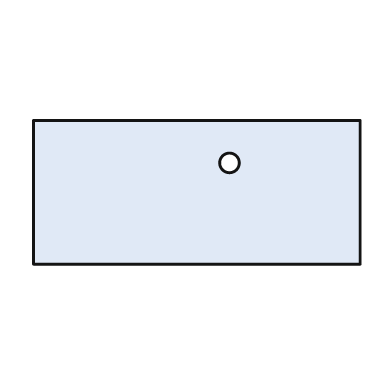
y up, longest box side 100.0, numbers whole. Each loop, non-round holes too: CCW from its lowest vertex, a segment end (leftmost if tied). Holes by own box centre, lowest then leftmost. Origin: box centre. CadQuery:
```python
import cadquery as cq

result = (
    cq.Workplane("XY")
    .moveTo(-50.0, -22.0)
    .lineTo(50.0, -22.0)
    .lineTo(50.0, 22.0)
    .lineTo(-50.0, 22.0)
    .close()
    .moveTo(10.0, 9.0)
    .circle(3.0)
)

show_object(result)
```